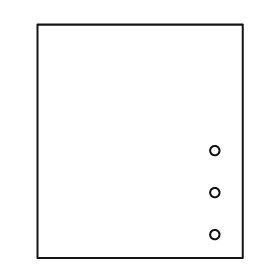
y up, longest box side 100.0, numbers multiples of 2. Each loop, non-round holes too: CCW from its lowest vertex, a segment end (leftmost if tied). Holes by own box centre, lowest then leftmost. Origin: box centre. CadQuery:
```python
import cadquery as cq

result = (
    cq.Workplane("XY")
    .moveTo(-44.0, -50.0)
    .lineTo(44.0, -50.0)
    .lineTo(44.0, 50.0)
    .lineTo(-44.0, 50.0)
    .close()
    .moveTo(32.0, -40.0)
    .circle(2.0)
    .moveTo(32.0, -22.0)
    .circle(2.0)
    .moveTo(32.0, -4.0)
    .circle(2.0)
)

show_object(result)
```